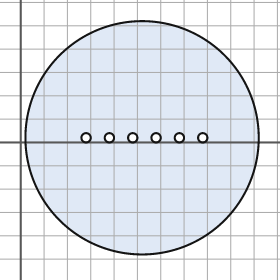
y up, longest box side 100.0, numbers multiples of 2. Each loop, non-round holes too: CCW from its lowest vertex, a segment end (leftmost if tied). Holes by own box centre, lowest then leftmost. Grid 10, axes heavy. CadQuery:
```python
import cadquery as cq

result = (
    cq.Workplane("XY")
    .moveTo(52.0, 2.0)
    .circle(50.0)
    .moveTo(28.0, 2.0)
    .circle(2.0)
    .moveTo(38.0, 2.0)
    .circle(2.0)
    .moveTo(48.0, 2.0)
    .circle(2.0)
    .moveTo(58.0, 2.0)
    .circle(2.0)
    .moveTo(68.0, 2.0)
    .circle(2.0)
    .moveTo(78.0, 2.0)
    .circle(2.0)
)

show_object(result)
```